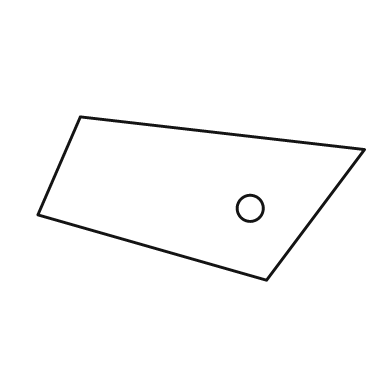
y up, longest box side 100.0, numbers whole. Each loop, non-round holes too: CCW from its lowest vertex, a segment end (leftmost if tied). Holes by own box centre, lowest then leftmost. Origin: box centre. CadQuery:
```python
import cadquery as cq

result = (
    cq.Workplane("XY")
    .moveTo(20.0, -25.0)
    .lineTo(50.0, 15.0)
    .lineTo(-37.0, 25.0)
    .lineTo(-50.0, -5.0)
    .close()
    .moveTo(15.0, -3.0)
    .circle(4.0)
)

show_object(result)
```